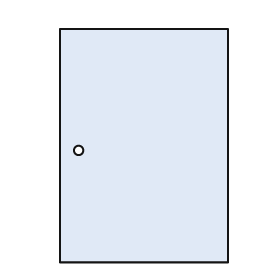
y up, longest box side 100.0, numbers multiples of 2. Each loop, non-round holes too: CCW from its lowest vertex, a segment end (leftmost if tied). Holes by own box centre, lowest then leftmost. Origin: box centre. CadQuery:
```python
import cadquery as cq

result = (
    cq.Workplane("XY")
    .moveTo(-36.0, -50.0)
    .lineTo(36.0, -50.0)
    .lineTo(36.0, 50.0)
    .lineTo(-36.0, 50.0)
    .close()
    .moveTo(-28.0, -2.0)
    .circle(2.0)
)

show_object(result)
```